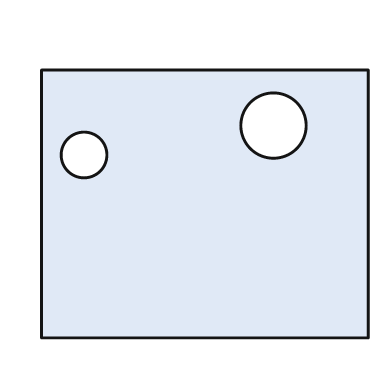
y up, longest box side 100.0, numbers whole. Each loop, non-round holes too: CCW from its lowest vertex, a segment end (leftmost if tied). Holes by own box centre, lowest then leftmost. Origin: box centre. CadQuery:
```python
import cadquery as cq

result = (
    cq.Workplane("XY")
    .moveTo(-50.0, -41.0)
    .lineTo(50.0, -41.0)
    .lineTo(50.0, 41.0)
    .lineTo(-50.0, 41.0)
    .close()
    .moveTo(-37.0, 15.0)
    .circle(7.0)
    .moveTo(21.0, 24.0)
    .circle(10.0)
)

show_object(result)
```